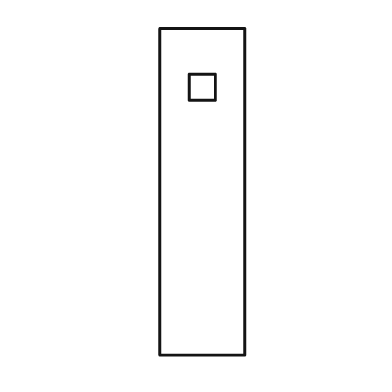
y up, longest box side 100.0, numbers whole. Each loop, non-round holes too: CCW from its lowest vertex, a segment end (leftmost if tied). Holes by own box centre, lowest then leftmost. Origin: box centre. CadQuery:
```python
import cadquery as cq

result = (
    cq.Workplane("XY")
    .moveTo(-13.0, -50.0)
    .lineTo(13.0, -50.0)
    .lineTo(13.0, 50.0)
    .lineTo(-13.0, 50.0)
    .close()
    .moveTo(-4.0, 28.0)
    .lineTo(4.0, 28.0)
    .lineTo(4.0, 36.0)
    .lineTo(-4.0, 36.0)
    .close()
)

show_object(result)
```